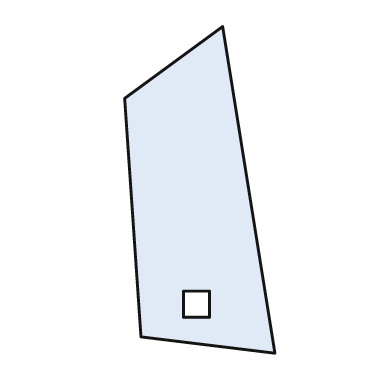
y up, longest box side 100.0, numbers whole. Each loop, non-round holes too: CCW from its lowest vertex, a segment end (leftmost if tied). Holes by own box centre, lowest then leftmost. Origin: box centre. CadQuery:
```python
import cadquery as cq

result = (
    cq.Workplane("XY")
    .moveTo(23.0, -50.0)
    .lineTo(7.0, 50.0)
    .lineTo(-23.0, 28.0)
    .lineTo(-18.0, -45.0)
    .close()
    .moveTo(-5.0, -39.0)
    .lineTo(3.0, -39.0)
    .lineTo(3.0, -31.0)
    .lineTo(-5.0, -31.0)
    .close()
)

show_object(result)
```